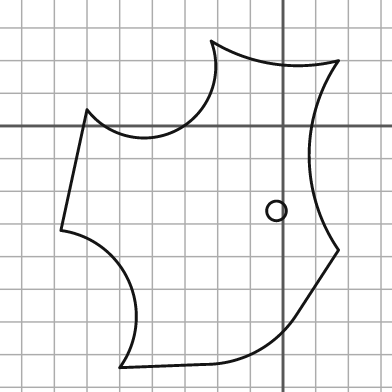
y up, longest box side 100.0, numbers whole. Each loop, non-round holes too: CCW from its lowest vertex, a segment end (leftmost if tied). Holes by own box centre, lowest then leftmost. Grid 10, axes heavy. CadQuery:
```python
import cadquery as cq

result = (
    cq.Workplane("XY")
    .moveTo(-50.0, -74.0)
    .lineTo(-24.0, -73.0)
    .threePointArc((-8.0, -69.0), (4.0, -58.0))
    .lineTo(17.0, -38.0)
    .threePointArc((8.0, -9.0), (17.0, 20.0))
    .threePointArc((-3.0, 19.0), (-22.0, 26.0))
    .threePointArc((-32.0, -1.0), (-60.0, 5.0))
    .lineTo(-68.0, -32.0)
    .threePointArc((-47.0, -48.0), (-50.0, -74.0))
    .close()
    .moveTo(-2.0, -26.0)
    .circle(3.0)
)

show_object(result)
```